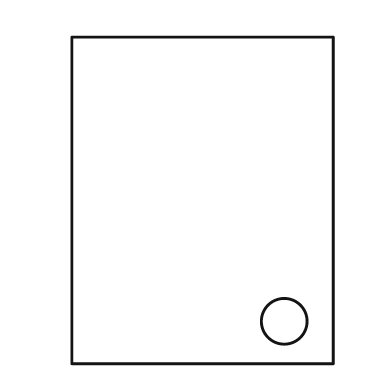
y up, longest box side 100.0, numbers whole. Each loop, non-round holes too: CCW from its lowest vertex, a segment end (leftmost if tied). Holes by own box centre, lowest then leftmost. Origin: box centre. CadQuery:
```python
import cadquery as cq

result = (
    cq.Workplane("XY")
    .moveTo(-40.0, -50.0)
    .lineTo(40.0, -50.0)
    .lineTo(40.0, 50.0)
    .lineTo(-40.0, 50.0)
    .close()
    .moveTo(25.0, -37.0)
    .circle(7.0)
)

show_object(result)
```